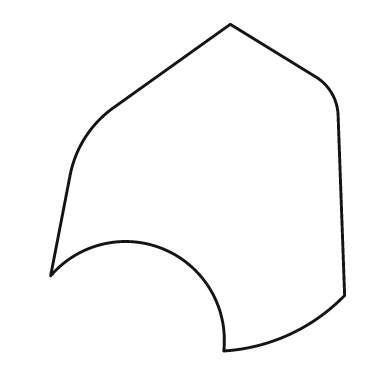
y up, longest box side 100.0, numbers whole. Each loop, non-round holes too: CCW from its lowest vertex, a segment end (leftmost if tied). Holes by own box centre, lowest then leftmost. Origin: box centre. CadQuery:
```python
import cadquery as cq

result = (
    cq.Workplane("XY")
    .moveTo(8.0, -50.0)
    .threePointArc((28.0, -45.0), (45.0, -33.0))
    .lineTo(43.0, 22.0)
    .threePointArc((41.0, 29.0), (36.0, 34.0))
    .lineTo(10.0, 50.0)
    .lineTo(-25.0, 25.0)
    .threePointArc((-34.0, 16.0), (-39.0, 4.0))
    .lineTo(-45.0, -27.0)
    .threePointArc((-10.0, -19.0), (8.0, -50.0))
    .close()
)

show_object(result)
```